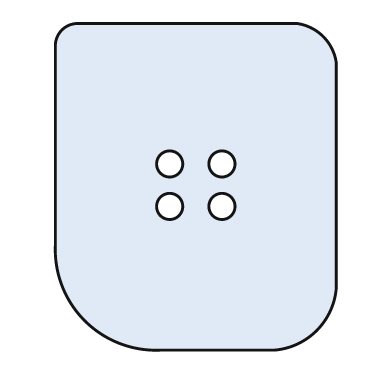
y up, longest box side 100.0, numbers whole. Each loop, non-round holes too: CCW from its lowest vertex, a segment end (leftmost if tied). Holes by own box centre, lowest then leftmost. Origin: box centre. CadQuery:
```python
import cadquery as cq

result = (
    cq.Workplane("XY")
    .moveTo(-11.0, -50.0)
    .lineTo(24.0, -50.0)
    .threePointArc((37.0, -44.0), (43.0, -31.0))
    .lineTo(43.0, 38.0)
    .threePointArc((39.0, 46.0), (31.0, 50.0))
    .lineTo(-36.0, 50.0)
    .threePointArc((-41.0, 48.0), (-43.0, 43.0))
    .lineTo(-43.0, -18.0)
    .threePointArc((-34.0, -41.0), (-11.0, -50.0))
    .close()
    .moveTo(-8.0, -6.0)
    .circle(4.0)
    .moveTo(8.0, -6.0)
    .circle(4.0)
    .moveTo(-8.0, 7.0)
    .circle(4.0)
    .moveTo(8.0, 7.0)
    .circle(4.0)
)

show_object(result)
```